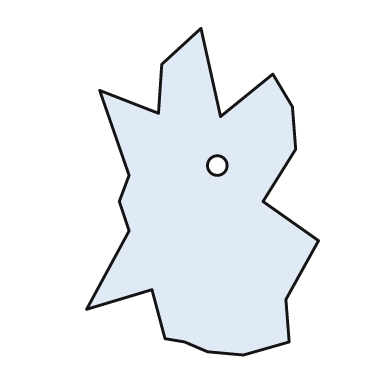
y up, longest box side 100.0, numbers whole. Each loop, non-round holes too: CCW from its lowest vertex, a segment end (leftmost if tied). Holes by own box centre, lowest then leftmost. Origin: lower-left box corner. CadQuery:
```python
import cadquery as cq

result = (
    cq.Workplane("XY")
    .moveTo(48.0, 0.0)
    .lineTo(62.0, 4.0)
    .lineTo(61.0, 17.0)
    .lineTo(71.0, 35.0)
    .lineTo(54.0, 47.0)
    .lineTo(64.0, 63.0)
    .lineTo(63.0, 76.0)
    .lineTo(57.0, 86.0)
    .lineTo(41.0, 73.0)
    .lineTo(35.0, 100.0)
    .lineTo(23.0, 89.0)
    .lineTo(22.0, 74.0)
    .lineTo(4.0, 81.0)
    .lineTo(13.0, 55.0)
    .lineTo(10.0, 47.0)
    .lineTo(13.0, 38.0)
    .lineTo(0.0, 14.0)
    .lineTo(20.0, 20.0)
    .lineTo(24.0, 5.0)
    .lineTo(30.0, 4.0)
    .lineTo(37.0, 1.0)
    .close()
    .moveTo(40.0, 58.0)
    .circle(3.0)
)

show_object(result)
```